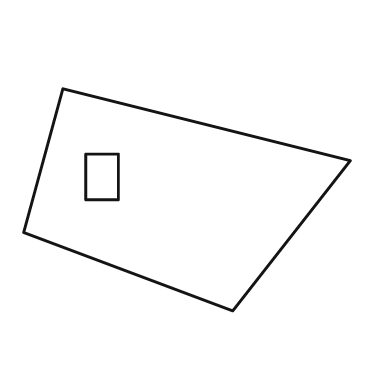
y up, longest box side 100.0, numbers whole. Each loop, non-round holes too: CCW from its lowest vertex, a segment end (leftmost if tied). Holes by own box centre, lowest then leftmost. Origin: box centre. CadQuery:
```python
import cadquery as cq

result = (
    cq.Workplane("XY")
    .moveTo(14.0, -34.0)
    .lineTo(50.0, 12.0)
    .lineTo(-38.0, 34.0)
    .lineTo(-50.0, -10.0)
    .close()
    .moveTo(-31.0, 0.0)
    .lineTo(-21.0, 0.0)
    .lineTo(-21.0, 14.0)
    .lineTo(-31.0, 14.0)
    .close()
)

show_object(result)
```